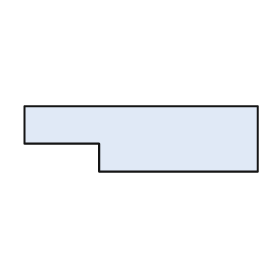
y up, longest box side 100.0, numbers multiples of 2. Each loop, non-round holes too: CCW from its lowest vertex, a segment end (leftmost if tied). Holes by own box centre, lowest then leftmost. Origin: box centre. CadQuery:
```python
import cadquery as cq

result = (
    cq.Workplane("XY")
    .moveTo(-18.0, -14.0)
    .lineTo(50.0, -14.0)
    .lineTo(50.0, 14.0)
    .lineTo(-50.0, 14.0)
    .lineTo(-50.0, -2.0)
    .lineTo(-18.0, -2.0)
    .close()
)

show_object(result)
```